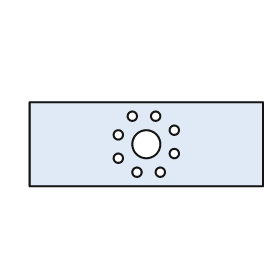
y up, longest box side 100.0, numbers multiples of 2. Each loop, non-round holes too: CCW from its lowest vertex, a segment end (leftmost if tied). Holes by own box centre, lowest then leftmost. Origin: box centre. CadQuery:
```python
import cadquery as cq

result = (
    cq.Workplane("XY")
    .moveTo(-50.0, -18.0)
    .lineTo(50.0, -18.0)
    .lineTo(50.0, 18.0)
    .lineTo(-50.0, 18.0)
    .close()
    .moveTo(-4.0, -12.0)
    .circle(2.0)
    .moveTo(6.0, -12.0)
    .circle(2.0)
    .moveTo(-12.0, -6.0)
    .circle(2.0)
    .moveTo(12.0, -4.0)
    .circle(2.0)
    .moveTo(0.0, 0.0)
    .circle(6.0)
    .moveTo(-12.0, 4.0)
    .circle(2.0)
    .moveTo(12.0, 6.0)
    .circle(2.0)
    .moveTo(-6.0, 12.0)
    .circle(2.0)
    .moveTo(4.0, 12.0)
    .circle(2.0)
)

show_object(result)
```